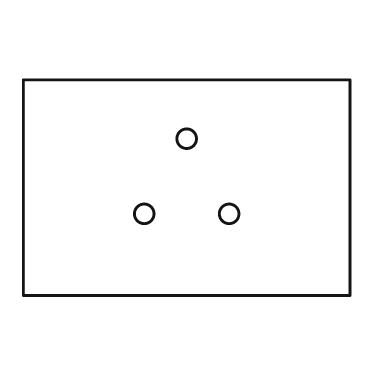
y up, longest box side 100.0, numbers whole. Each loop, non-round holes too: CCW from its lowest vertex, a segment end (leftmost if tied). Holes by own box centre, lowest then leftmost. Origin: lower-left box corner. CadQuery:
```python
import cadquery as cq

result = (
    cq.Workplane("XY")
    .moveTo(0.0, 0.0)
    .lineTo(100.0, 0.0)
    .lineTo(100.0, 66.0)
    .lineTo(0.0, 66.0)
    .close()
    .moveTo(37.0, 25.0)
    .circle(3.0)
    .moveTo(63.0, 25.0)
    .circle(3.0)
    .moveTo(50.0, 48.0)
    .circle(3.0)
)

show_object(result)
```